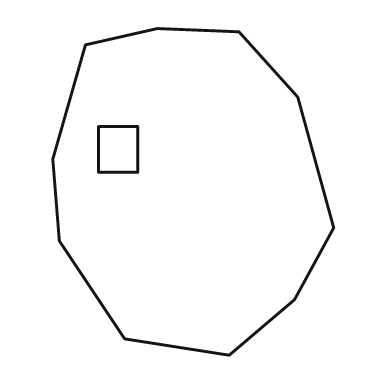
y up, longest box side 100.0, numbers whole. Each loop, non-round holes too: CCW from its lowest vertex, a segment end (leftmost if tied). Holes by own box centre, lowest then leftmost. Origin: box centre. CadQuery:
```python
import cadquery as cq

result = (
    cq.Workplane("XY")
    .moveTo(11.0, -50.0)
    .lineTo(31.0, -33.0)
    .lineTo(43.0, -11.0)
    .lineTo(32.0, 29.0)
    .lineTo(14.0, 49.0)
    .lineTo(-11.0, 50.0)
    .lineTo(-33.0, 45.0)
    .lineTo(-43.0, 10.0)
    .lineTo(-41.0, -15.0)
    .lineTo(-21.0, -45.0)
    .close()
    .moveTo(-29.0, 6.0)
    .lineTo(-17.0, 6.0)
    .lineTo(-17.0, 20.0)
    .lineTo(-29.0, 20.0)
    .close()
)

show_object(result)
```